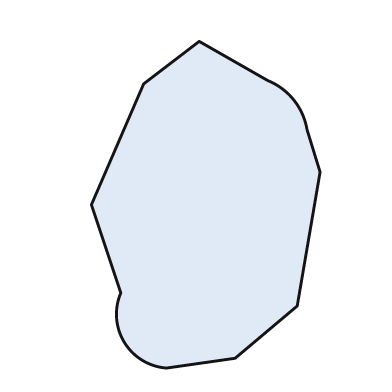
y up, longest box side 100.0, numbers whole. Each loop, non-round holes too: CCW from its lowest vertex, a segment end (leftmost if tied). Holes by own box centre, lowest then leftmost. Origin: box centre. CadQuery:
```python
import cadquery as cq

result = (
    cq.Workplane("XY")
    .moveTo(-12.0, -50.0)
    .lineTo(9.0, -47.0)
    .lineTo(28.0, -31.0)
    .lineTo(35.0, 10.0)
    .lineTo(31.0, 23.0)
    .threePointArc((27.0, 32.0), (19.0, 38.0))
    .lineTo(-2.0, 50.0)
    .lineTo(-19.0, 37.0)
    .lineTo(-35.0, 0.0)
    .lineTo(-26.0, -27.0)
    .threePointArc((-25.0, -42.0), (-12.0, -50.0))
    .close()
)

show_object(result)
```